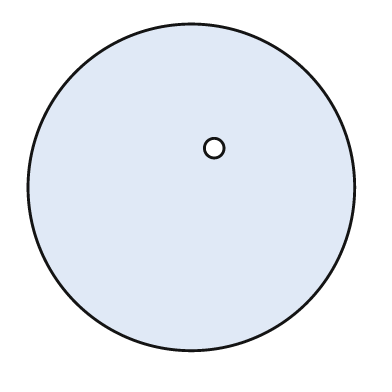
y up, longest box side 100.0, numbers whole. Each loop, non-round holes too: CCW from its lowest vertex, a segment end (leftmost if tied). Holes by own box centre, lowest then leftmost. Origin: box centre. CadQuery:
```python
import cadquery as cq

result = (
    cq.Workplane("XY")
    .moveTo(0.0, 0.0)
    .circle(50.0)
    .moveTo(7.0, 12.0)
    .circle(3.0)
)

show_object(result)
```